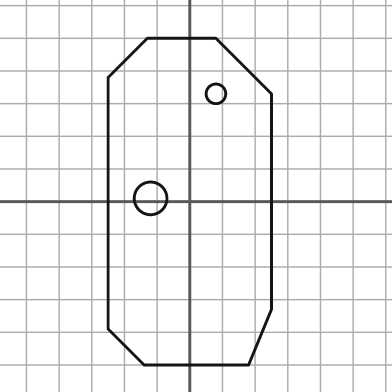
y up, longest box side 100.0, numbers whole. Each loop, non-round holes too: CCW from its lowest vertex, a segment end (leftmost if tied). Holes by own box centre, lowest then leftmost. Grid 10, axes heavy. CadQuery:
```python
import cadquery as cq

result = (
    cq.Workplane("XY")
    .moveTo(-14.0, -50.0)
    .lineTo(18.0, -50.0)
    .lineTo(25.0, -33.0)
    .lineTo(25.0, 33.0)
    .lineTo(8.0, 50.0)
    .lineTo(-13.0, 50.0)
    .lineTo(-25.0, 38.0)
    .lineTo(-25.0, -39.0)
    .close()
    .moveTo(-12.0, 1.0)
    .circle(5.0)
    .moveTo(8.0, 33.0)
    .circle(3.0)
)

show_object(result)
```